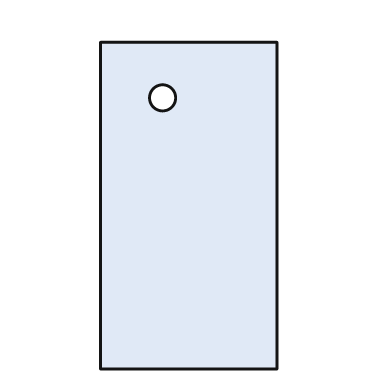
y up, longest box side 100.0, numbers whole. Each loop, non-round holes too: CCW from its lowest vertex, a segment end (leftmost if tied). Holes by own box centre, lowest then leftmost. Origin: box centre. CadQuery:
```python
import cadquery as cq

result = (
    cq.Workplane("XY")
    .moveTo(-27.0, -50.0)
    .lineTo(27.0, -50.0)
    .lineTo(27.0, 50.0)
    .lineTo(-27.0, 50.0)
    .close()
    .moveTo(-8.0, 33.0)
    .circle(4.0)
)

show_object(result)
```